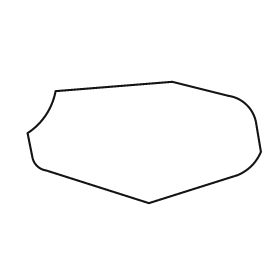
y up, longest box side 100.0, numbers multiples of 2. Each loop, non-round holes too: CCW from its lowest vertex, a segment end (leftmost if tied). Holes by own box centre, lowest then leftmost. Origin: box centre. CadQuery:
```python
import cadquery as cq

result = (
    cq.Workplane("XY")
    .moveTo(2.0, -26.0)
    .lineTo(40.0, -14.0)
    .threePointArc((46.0, -10.0), (50.0, -4.0))
    .lineTo(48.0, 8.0)
    .threePointArc((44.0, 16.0), (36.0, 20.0))
    .lineTo(12.0, 26.0)
    .lineTo(-38.0, 22.0)
    .threePointArc((-42.0, 12.0), (-50.0, 4.0))
    .lineTo(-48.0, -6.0)
    .threePointArc((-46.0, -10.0), (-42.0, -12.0))
    .close()
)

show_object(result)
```